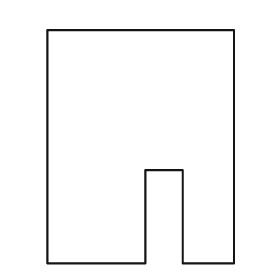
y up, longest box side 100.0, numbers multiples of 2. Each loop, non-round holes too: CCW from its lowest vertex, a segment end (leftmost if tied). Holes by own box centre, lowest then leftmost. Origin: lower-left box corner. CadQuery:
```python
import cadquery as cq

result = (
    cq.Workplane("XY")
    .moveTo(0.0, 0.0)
    .lineTo(42.0, 0.0)
    .lineTo(42.0, 40.0)
    .lineTo(58.0, 40.0)
    .lineTo(58.0, 0.0)
    .lineTo(80.0, 0.0)
    .lineTo(80.0, 100.0)
    .lineTo(0.0, 100.0)
    .close()
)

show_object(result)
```